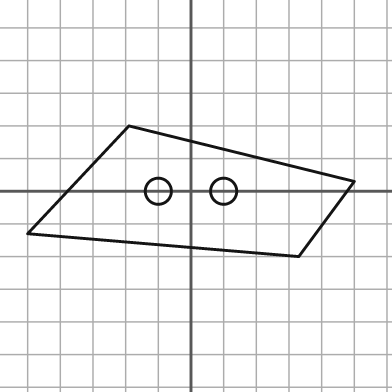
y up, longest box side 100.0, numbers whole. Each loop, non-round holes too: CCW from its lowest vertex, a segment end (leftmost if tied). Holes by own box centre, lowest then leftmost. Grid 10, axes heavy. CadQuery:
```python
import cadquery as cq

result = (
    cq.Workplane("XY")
    .moveTo(33.0, -20.0)
    .lineTo(50.0, 3.0)
    .lineTo(-19.0, 20.0)
    .lineTo(-50.0, -13.0)
    .close()
    .moveTo(-10.0, 0.0)
    .circle(4.0)
    .moveTo(10.0, 0.0)
    .circle(4.0)
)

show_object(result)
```